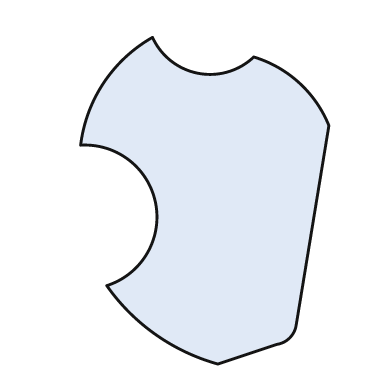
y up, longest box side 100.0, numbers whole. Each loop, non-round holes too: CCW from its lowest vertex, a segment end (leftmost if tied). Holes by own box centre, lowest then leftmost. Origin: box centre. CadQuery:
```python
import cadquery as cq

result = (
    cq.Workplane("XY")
    .moveTo(4.0, -50.0)
    .lineTo(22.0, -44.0)
    .threePointArc((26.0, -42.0), (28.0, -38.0))
    .lineTo(38.0, 23.0)
    .threePointArc((29.0, 36.0), (15.0, 44.0))
    .threePointArc((-2.0, 39.0), (-16.0, 50.0))
    .threePointArc((-31.0, 36.0), (-38.0, 17.0))
    .threePointArc((-15.0, -1.0), (-30.0, -26.0))
    .threePointArc((-15.0, -41.0), (4.0, -50.0))
    .close()
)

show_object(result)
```